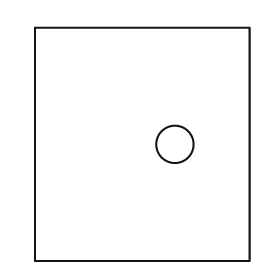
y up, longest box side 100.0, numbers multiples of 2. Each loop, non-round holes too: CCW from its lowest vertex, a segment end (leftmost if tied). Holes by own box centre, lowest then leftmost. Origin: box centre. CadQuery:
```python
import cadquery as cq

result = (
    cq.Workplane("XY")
    .moveTo(-46.0, -50.0)
    .lineTo(46.0, -50.0)
    .lineTo(46.0, 50.0)
    .lineTo(-46.0, 50.0)
    .close()
    .moveTo(14.0, 0.0)
    .circle(8.0)
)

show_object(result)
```